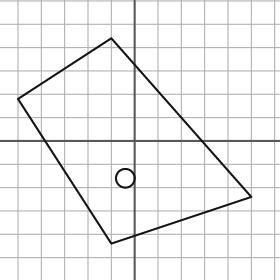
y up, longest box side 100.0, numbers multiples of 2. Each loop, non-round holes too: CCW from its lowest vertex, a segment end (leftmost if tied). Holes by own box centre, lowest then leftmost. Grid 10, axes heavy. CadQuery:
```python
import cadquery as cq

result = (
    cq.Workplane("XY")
    .moveTo(-10.0, -44.0)
    .lineTo(50.0, -24.0)
    .lineTo(-10.0, 44.0)
    .lineTo(-50.0, 18.0)
    .close()
    .moveTo(-4.0, -16.0)
    .circle(4.0)
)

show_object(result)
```